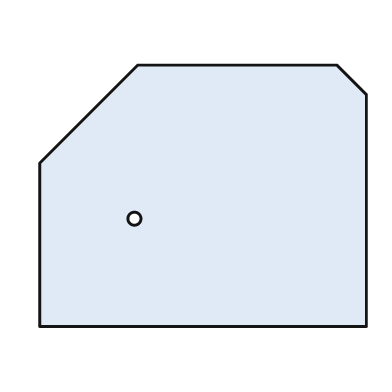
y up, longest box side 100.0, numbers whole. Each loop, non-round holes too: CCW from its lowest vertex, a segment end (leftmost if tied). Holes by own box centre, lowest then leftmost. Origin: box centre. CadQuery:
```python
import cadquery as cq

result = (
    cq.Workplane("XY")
    .moveTo(-50.0, -40.0)
    .lineTo(50.0, -40.0)
    .lineTo(50.0, 31.0)
    .lineTo(41.0, 40.0)
    .lineTo(-20.0, 40.0)
    .lineTo(-50.0, 10.0)
    .close()
    .moveTo(-21.0, -7.0)
    .circle(2.0)
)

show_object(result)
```